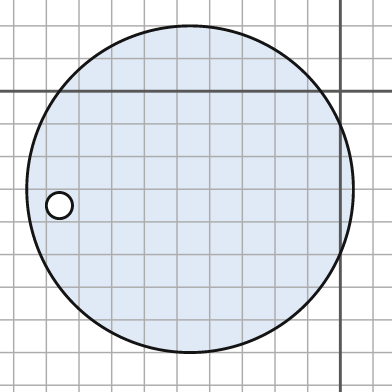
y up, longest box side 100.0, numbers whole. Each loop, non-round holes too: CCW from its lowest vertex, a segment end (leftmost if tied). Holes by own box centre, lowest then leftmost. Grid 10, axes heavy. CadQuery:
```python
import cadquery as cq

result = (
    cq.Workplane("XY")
    .moveTo(-46.0, -30.0)
    .circle(50.0)
    .moveTo(-86.0, -35.0)
    .circle(4.0)
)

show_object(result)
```